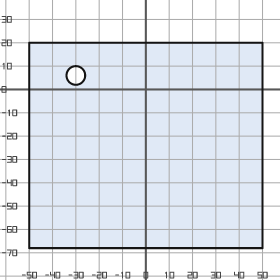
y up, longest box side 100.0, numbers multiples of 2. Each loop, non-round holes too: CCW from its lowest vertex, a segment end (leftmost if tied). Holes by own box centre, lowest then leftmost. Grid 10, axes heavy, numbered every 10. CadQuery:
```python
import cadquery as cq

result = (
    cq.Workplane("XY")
    .moveTo(-50.0, -68.0)
    .lineTo(50.0, -68.0)
    .lineTo(50.0, 20.0)
    .lineTo(-50.0, 20.0)
    .close()
    .moveTo(-30.0, 6.0)
    .circle(4.0)
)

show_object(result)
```